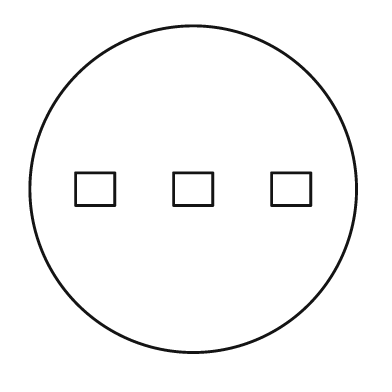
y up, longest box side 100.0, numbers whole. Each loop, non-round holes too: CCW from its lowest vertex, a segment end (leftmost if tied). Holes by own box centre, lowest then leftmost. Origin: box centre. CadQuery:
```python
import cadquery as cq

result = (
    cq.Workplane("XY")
    .moveTo(0.0, 0.0)
    .circle(50.0)
    .moveTo(-36.0, -5.0)
    .lineTo(-24.0, -5.0)
    .lineTo(-24.0, 5.0)
    .lineTo(-36.0, 5.0)
    .close()
    .moveTo(-6.0, -5.0)
    .lineTo(6.0, -5.0)
    .lineTo(6.0, 5.0)
    .lineTo(-6.0, 5.0)
    .close()
    .moveTo(24.0, -5.0)
    .lineTo(36.0, -5.0)
    .lineTo(36.0, 5.0)
    .lineTo(24.0, 5.0)
    .close()
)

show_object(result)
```